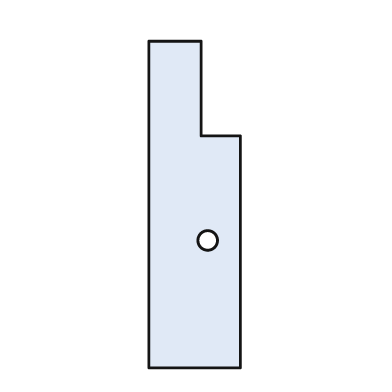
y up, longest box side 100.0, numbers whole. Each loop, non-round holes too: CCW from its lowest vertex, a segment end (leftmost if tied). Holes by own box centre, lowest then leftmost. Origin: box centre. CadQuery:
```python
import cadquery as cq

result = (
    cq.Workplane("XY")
    .moveTo(-14.0, -50.0)
    .lineTo(14.0, -50.0)
    .lineTo(14.0, 21.0)
    .lineTo(2.0, 21.0)
    .lineTo(2.0, 50.0)
    .lineTo(-14.0, 50.0)
    .close()
    .moveTo(4.0, -11.0)
    .circle(3.0)
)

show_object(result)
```